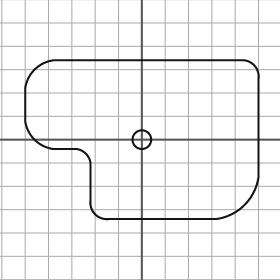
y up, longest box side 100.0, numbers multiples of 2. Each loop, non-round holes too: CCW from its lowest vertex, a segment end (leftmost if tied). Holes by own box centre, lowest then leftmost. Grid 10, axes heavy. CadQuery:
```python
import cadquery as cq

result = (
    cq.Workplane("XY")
    .moveTo(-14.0, -34.0)
    .lineTo(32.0, -34.0)
    .threePointArc((44.0, -28.0), (50.0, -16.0))
    .lineTo(50.0, 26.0)
    .threePointArc((48.0, 32.0), (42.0, 34.0))
    .lineTo(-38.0, 34.0)
    .threePointArc((-46.0, 30.0), (-50.0, 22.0))
    .lineTo(-50.0, 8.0)
    .threePointArc((-46.0, 0.0), (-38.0, -4.0))
    .lineTo(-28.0, -4.0)
    .threePointArc((-24.0, -6.0), (-22.0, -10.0))
    .lineTo(-22.0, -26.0)
    .threePointArc((-20.0, -32.0), (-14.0, -34.0))
    .close()
    .moveTo(0.0, 0.0)
    .circle(4.0)
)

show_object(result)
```